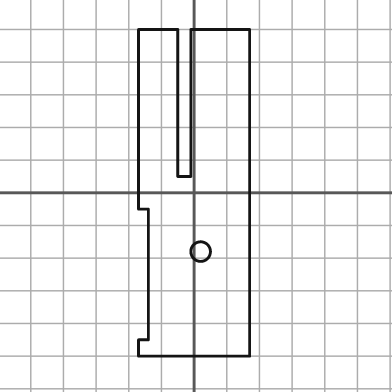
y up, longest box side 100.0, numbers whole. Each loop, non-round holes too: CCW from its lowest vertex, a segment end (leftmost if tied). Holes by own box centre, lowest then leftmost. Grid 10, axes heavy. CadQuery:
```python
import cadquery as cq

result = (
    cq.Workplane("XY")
    .moveTo(-17.0, -50.0)
    .lineTo(17.0, -50.0)
    .lineTo(17.0, 50.0)
    .lineTo(-1.0, 50.0)
    .lineTo(-1.0, 5.0)
    .lineTo(-5.0, 5.0)
    .lineTo(-5.0, 50.0)
    .lineTo(-17.0, 50.0)
    .lineTo(-17.0, -5.0)
    .lineTo(-14.0, -5.0)
    .lineTo(-14.0, -45.0)
    .lineTo(-17.0, -45.0)
    .close()
    .moveTo(2.0, -18.0)
    .circle(3.0)
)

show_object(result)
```